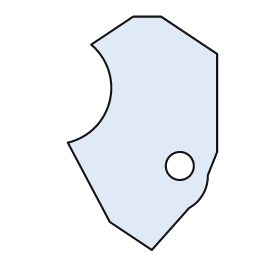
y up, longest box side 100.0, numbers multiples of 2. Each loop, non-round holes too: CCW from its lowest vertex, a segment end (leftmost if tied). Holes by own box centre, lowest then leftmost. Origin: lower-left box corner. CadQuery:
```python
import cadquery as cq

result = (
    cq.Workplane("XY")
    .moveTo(36.0, 0.0)
    .lineTo(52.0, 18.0)
    .threePointArc((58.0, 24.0), (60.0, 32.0))
    .lineTo(64.0, 42.0)
    .lineTo(64.0, 84.0)
    .lineTo(40.0, 100.0)
    .lineTo(28.0, 100.0)
    .lineTo(10.0, 88.0)
    .threePointArc((18.0, 64.0), (0.0, 46.0))
    .lineTo(18.0, 12.0)
    .close()
    .moveTo(48.0, 36.0)
    .circle(6.0)
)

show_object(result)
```